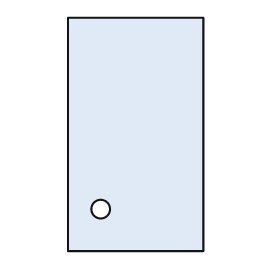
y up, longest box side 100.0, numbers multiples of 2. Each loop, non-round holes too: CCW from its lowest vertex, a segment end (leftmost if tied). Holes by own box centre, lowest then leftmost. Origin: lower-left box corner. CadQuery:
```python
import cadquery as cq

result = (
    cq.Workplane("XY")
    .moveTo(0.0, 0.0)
    .lineTo(58.0, 0.0)
    .lineTo(58.0, 100.0)
    .lineTo(0.0, 100.0)
    .close()
    .moveTo(14.0, 18.0)
    .circle(4.0)
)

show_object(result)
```